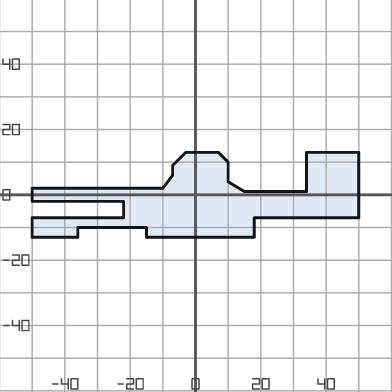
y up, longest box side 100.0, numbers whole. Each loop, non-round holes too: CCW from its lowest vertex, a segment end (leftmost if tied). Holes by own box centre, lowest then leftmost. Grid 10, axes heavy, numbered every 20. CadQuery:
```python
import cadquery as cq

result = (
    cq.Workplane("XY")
    .moveTo(-50.0, -13.0)
    .lineTo(-36.0, -13.0)
    .lineTo(-36.0, -10.0)
    .lineTo(-15.0, -10.0)
    .lineTo(-15.0, -13.0)
    .lineTo(18.0, -13.0)
    .lineTo(18.0, -7.0)
    .lineTo(50.0, -7.0)
    .lineTo(50.0, 13.0)
    .lineTo(34.0, 13.0)
    .lineTo(34.0, 1.0)
    .lineTo(15.0, 1.0)
    .lineTo(10.0, 4.0)
    .lineTo(10.0, 10.0)
    .lineTo(7.0, 13.0)
    .lineTo(-3.0, 13.0)
    .lineTo(-7.0, 9.0)
    .lineTo(-7.0, 6.0)
    .lineTo(-10.0, 2.0)
    .lineTo(-50.0, 2.0)
    .lineTo(-50.0, -2.0)
    .lineTo(-22.0, -2.0)
    .lineTo(-22.0, -7.0)
    .lineTo(-50.0, -7.0)
    .close()
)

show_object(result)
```